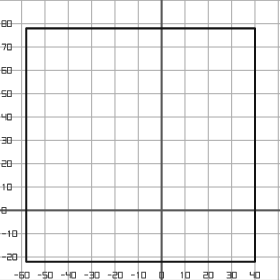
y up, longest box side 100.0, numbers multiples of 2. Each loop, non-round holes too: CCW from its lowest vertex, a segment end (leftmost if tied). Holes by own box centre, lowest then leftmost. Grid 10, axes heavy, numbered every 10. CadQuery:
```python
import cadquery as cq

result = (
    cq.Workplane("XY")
    .moveTo(-58.0, -22.0)
    .lineTo(40.0, -22.0)
    .lineTo(40.0, 78.0)
    .lineTo(-58.0, 78.0)
    .close()
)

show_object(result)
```